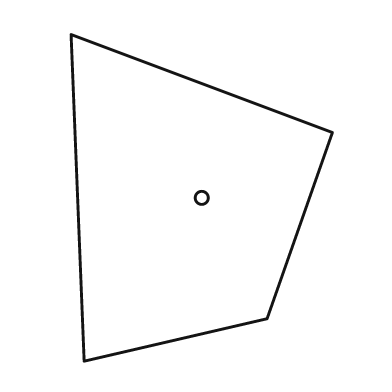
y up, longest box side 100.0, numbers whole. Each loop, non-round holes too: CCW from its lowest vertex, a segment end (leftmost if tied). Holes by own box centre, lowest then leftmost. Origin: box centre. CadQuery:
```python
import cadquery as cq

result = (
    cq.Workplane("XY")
    .moveTo(-36.0, -50.0)
    .lineTo(20.0, -37.0)
    .lineTo(40.0, 20.0)
    .lineTo(-40.0, 50.0)
    .close()
    .moveTo(0.0, 0.0)
    .circle(2.0)
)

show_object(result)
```